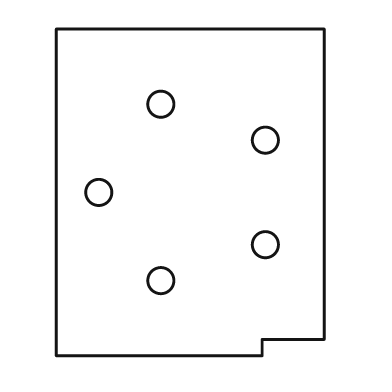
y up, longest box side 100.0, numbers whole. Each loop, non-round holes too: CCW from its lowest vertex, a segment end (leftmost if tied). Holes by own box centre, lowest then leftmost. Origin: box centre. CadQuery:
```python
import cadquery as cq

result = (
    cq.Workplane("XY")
    .moveTo(-41.0, -50.0)
    .lineTo(22.0, -50.0)
    .lineTo(22.0, -45.0)
    .lineTo(41.0, -45.0)
    .lineTo(41.0, 50.0)
    .lineTo(-41.0, 50.0)
    .close()
    .moveTo(-9.0, -27.0)
    .circle(4.0)
    .moveTo(23.0, -16.0)
    .circle(4.0)
    .moveTo(-28.0, 0.0)
    .circle(4.0)
    .moveTo(23.0, 16.0)
    .circle(4.0)
    .moveTo(-9.0, 27.0)
    .circle(4.0)
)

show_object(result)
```